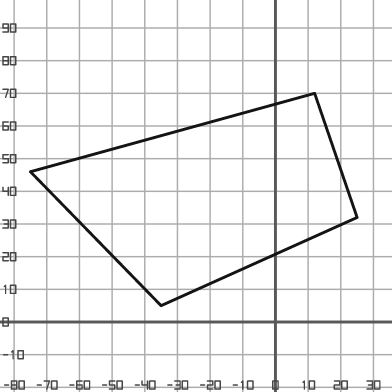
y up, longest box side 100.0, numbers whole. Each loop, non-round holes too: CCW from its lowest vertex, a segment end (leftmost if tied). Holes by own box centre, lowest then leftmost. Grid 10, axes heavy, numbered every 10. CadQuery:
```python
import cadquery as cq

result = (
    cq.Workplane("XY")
    .moveTo(-35.0, 5.0)
    .lineTo(25.0, 32.0)
    .lineTo(12.0, 70.0)
    .lineTo(-75.0, 46.0)
    .close()
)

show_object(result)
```